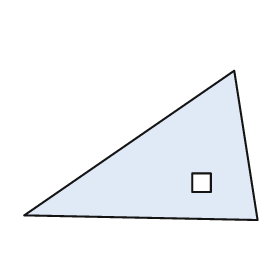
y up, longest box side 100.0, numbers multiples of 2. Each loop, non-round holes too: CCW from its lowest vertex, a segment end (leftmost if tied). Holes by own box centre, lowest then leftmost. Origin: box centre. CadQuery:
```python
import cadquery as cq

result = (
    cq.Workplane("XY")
    .moveTo(50.0, -32.0)
    .lineTo(40.0, 32.0)
    .lineTo(-50.0, -30.0)
    .close()
    .moveTo(22.0, -20.0)
    .lineTo(30.0, -20.0)
    .lineTo(30.0, -12.0)
    .lineTo(22.0, -12.0)
    .close()
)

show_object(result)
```